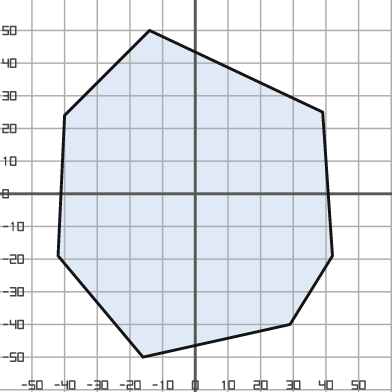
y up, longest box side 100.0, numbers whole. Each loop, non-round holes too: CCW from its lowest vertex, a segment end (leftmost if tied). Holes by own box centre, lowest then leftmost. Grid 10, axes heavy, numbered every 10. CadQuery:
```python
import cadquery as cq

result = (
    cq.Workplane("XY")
    .moveTo(-16.0, -50.0)
    .lineTo(29.0, -40.0)
    .lineTo(42.0, -19.0)
    .lineTo(39.0, 25.0)
    .lineTo(-14.0, 50.0)
    .lineTo(-40.0, 24.0)
    .lineTo(-42.0, -19.0)
    .close()
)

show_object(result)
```